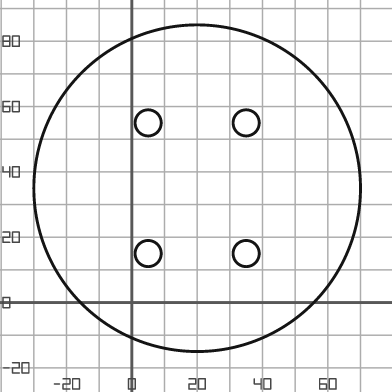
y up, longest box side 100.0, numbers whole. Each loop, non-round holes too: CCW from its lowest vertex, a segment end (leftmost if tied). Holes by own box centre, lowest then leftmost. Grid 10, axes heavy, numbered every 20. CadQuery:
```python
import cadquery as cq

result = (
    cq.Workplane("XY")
    .moveTo(20.0, 35.0)
    .circle(50.0)
    .moveTo(5.0, 15.0)
    .circle(4.0)
    .moveTo(35.0, 15.0)
    .circle(4.0)
    .moveTo(5.0, 55.0)
    .circle(4.0)
    .moveTo(35.0, 55.0)
    .circle(4.0)
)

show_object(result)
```